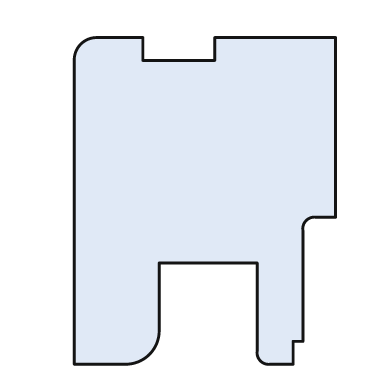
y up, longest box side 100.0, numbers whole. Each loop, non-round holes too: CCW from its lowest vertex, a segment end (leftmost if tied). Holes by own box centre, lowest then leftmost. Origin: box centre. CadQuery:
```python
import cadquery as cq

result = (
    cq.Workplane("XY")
    .moveTo(-40.0, -50.0)
    .lineTo(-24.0, -50.0)
    .threePointArc((-17.0, -47.0), (-14.0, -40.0))
    .lineTo(-14.0, -19.0)
    .lineTo(16.0, -19.0)
    .lineTo(16.0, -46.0)
    .threePointArc((17.0, -49.0), (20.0, -50.0))
    .lineTo(27.0, -50.0)
    .lineTo(27.0, -43.0)
    .lineTo(30.0, -43.0)
    .lineTo(30.0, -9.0)
    .threePointArc((31.0, -6.0), (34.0, -5.0))
    .lineTo(40.0, -5.0)
    .lineTo(40.0, 50.0)
    .lineTo(3.0, 50.0)
    .lineTo(3.0, 43.0)
    .lineTo(-19.0, 43.0)
    .lineTo(-19.0, 50.0)
    .lineTo(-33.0, 50.0)
    .threePointArc((-38.0, 48.0), (-40.0, 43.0))
    .close()
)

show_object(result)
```